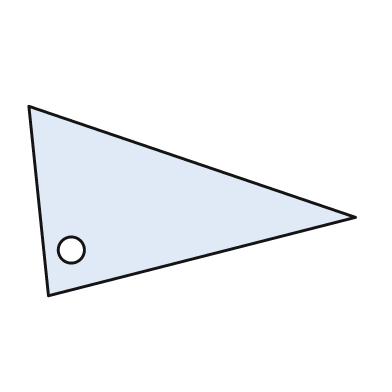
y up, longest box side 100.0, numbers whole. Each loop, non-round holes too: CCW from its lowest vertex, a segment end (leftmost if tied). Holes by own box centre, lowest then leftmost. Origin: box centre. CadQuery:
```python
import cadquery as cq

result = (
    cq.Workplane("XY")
    .moveTo(-44.0, -29.0)
    .lineTo(50.0, -5.0)
    .lineTo(-50.0, 29.0)
    .close()
    .moveTo(-37.0, -15.0)
    .circle(4.0)
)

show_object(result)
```